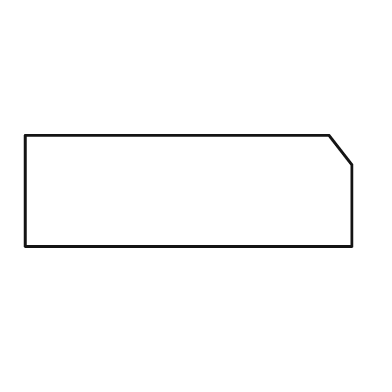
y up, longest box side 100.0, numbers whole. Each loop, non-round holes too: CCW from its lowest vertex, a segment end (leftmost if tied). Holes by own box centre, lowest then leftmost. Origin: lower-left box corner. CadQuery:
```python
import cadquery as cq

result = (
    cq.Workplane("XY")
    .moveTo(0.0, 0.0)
    .lineTo(100.0, 0.0)
    .lineTo(100.0, 25.0)
    .lineTo(93.0, 34.0)
    .lineTo(0.0, 34.0)
    .close()
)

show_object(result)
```